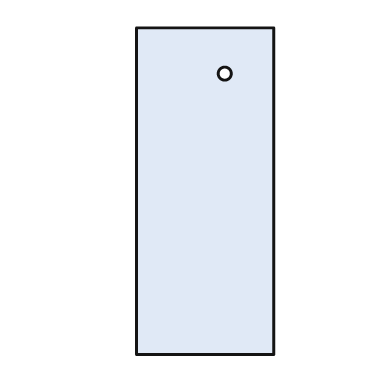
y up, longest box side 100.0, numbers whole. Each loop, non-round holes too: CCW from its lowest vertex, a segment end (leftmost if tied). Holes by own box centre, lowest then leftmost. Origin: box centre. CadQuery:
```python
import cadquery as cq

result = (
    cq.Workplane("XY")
    .moveTo(-21.0, -50.0)
    .lineTo(21.0, -50.0)
    .lineTo(21.0, 50.0)
    .lineTo(-21.0, 50.0)
    .close()
    .moveTo(6.0, 36.0)
    .circle(2.0)
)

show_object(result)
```